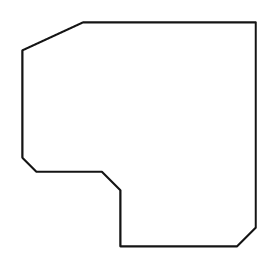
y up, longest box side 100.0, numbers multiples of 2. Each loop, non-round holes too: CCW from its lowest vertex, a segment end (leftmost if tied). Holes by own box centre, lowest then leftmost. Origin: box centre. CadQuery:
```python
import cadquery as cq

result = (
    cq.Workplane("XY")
    .moveTo(-8.0, -48.0)
    .lineTo(42.0, -48.0)
    .lineTo(50.0, -40.0)
    .lineTo(50.0, 48.0)
    .lineTo(-24.0, 48.0)
    .lineTo(-50.0, 36.0)
    .lineTo(-50.0, -10.0)
    .lineTo(-44.0, -16.0)
    .lineTo(-16.0, -16.0)
    .lineTo(-8.0, -24.0)
    .close()
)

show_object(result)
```